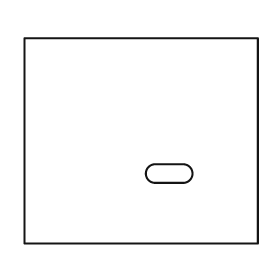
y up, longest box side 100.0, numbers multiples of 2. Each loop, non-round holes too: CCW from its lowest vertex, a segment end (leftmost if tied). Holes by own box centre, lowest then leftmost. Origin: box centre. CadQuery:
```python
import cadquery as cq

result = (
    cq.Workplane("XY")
    .moveTo(-50.0, -44.0)
    .lineTo(50.0, -44.0)
    .lineTo(50.0, 44.0)
    .lineTo(-50.0, 44.0)
    .close()
    .moveTo(6.0, -18.0)
    .lineTo(18.0, -18.0)
    .threePointArc((22.0, -14.0), (18.0, -10.0))
    .lineTo(6.0, -10.0)
    .threePointArc((2.0, -14.0), (6.0, -18.0))
    .close()
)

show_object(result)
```